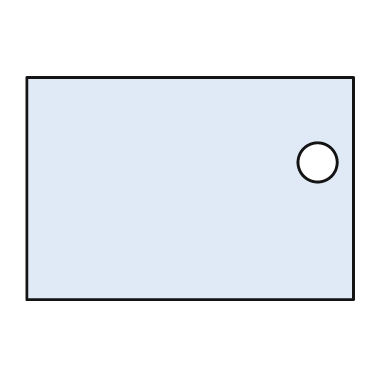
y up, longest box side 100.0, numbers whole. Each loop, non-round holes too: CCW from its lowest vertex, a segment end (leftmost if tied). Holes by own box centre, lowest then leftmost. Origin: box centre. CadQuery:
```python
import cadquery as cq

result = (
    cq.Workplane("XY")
    .moveTo(-50.0, -34.0)
    .lineTo(50.0, -34.0)
    .lineTo(50.0, 34.0)
    .lineTo(-50.0, 34.0)
    .close()
    .moveTo(39.0, 8.0)
    .circle(6.0)
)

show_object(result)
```